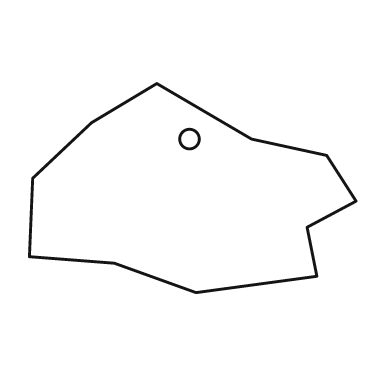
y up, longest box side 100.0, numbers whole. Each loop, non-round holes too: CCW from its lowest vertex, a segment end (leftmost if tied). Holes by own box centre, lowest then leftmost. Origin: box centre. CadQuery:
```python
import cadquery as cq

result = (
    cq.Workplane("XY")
    .moveTo(1.0, -32.0)
    .lineTo(38.0, -27.0)
    .lineTo(35.0, -12.0)
    .lineTo(50.0, -4.0)
    .lineTo(41.0, 10.0)
    .lineTo(18.0, 15.0)
    .lineTo(-11.0, 32.0)
    .lineTo(-31.0, 20.0)
    .lineTo(-49.0, 3.0)
    .lineTo(-50.0, -21.0)
    .lineTo(-24.0, -23.0)
    .close()
    .moveTo(-1.0, 15.0)
    .circle(3.0)
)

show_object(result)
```